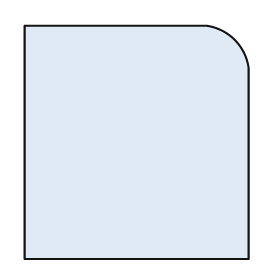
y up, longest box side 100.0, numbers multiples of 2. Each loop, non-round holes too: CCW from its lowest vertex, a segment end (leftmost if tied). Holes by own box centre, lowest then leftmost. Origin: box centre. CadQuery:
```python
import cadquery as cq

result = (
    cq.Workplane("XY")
    .moveTo(-48.0, -50.0)
    .lineTo(48.0, -50.0)
    .lineTo(48.0, 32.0)
    .threePointArc((42.0, 44.0), (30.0, 50.0))
    .lineTo(-48.0, 50.0)
    .close()
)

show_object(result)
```